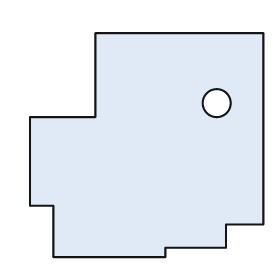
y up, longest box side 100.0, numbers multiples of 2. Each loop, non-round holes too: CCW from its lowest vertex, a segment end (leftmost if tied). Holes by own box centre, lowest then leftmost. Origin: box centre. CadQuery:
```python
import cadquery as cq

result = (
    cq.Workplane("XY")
    .moveTo(-40.0, -48.0)
    .lineTo(8.0, -48.0)
    .lineTo(8.0, -44.0)
    .lineTo(34.0, -44.0)
    .lineTo(34.0, -34.0)
    .lineTo(50.0, -34.0)
    .lineTo(50.0, 48.0)
    .lineTo(-22.0, 48.0)
    .lineTo(-22.0, 12.0)
    .lineTo(-50.0, 12.0)
    .lineTo(-50.0, -26.0)
    .lineTo(-40.0, -26.0)
    .close()
    .moveTo(30.0, 18.0)
    .circle(6.0)
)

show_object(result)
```